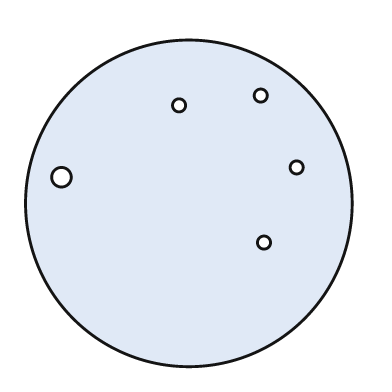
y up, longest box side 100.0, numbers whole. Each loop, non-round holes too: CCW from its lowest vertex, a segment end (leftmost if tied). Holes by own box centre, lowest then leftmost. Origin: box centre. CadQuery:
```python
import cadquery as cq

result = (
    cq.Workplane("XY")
    .moveTo(0.0, 0.0)
    .circle(50.0)
    .moveTo(23.0, -12.0)
    .circle(2.0)
    .moveTo(-39.0, 8.0)
    .circle(3.0)
    .moveTo(33.0, 11.0)
    .circle(2.0)
    .moveTo(-3.0, 30.0)
    .circle(2.0)
    .moveTo(22.0, 33.0)
    .circle(2.0)
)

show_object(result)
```